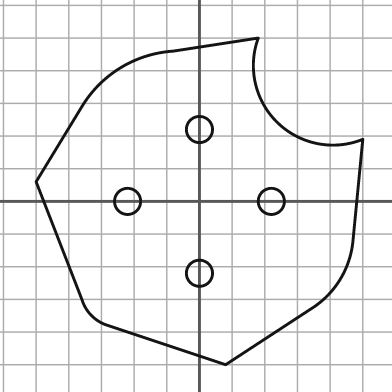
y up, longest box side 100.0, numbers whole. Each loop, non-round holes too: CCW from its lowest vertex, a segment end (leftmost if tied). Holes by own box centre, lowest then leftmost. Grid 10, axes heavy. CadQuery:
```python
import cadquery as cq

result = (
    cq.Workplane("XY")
    .moveTo(8.0, -50.0)
    .lineTo(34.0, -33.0)
    .threePointArc((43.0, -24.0), (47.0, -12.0))
    .lineTo(50.0, 19.0)
    .threePointArc((24.0, 24.0), (18.0, 50.0))
    .lineTo(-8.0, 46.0)
    .threePointArc((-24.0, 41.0), (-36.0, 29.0))
    .lineTo(-50.0, 6.0)
    .lineTo(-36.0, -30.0)
    .threePointArc((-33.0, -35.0), (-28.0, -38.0))
    .close()
    .moveTo(0.0, -22.0)
    .circle(4.0)
    .moveTo(-22.0, 0.0)
    .circle(4.0)
    .moveTo(22.0, 0.0)
    .circle(4.0)
    .moveTo(0.0, 22.0)
    .circle(4.0)
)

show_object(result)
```